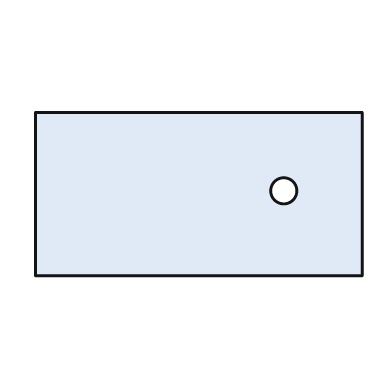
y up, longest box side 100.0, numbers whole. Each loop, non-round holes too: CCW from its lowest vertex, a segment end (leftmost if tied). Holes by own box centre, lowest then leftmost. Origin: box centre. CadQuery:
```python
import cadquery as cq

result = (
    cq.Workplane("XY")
    .moveTo(-50.0, -25.0)
    .lineTo(50.0, -25.0)
    .lineTo(50.0, 25.0)
    .lineTo(-50.0, 25.0)
    .close()
    .moveTo(26.0, 1.0)
    .circle(4.0)
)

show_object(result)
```